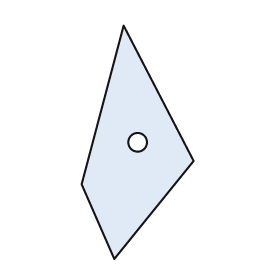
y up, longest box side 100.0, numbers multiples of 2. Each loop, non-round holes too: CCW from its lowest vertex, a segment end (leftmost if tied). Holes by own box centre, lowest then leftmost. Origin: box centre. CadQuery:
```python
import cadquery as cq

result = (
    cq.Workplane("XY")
    .moveTo(-10.0, -50.0)
    .lineTo(24.0, -8.0)
    .lineTo(-6.0, 50.0)
    .lineTo(-24.0, -18.0)
    .close()
    .moveTo(0.0, 0.0)
    .circle(4.0)
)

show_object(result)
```